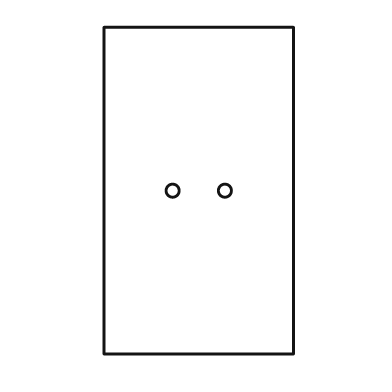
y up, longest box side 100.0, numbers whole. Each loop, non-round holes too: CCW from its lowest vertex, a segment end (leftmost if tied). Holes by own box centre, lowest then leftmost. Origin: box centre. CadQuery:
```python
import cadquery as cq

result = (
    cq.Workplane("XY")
    .moveTo(-29.0, -50.0)
    .lineTo(29.0, -50.0)
    .lineTo(29.0, 50.0)
    .lineTo(-29.0, 50.0)
    .close()
    .moveTo(-8.0, 0.0)
    .circle(2.0)
    .moveTo(8.0, 0.0)
    .circle(2.0)
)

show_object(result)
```